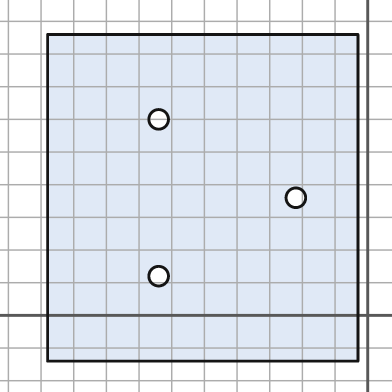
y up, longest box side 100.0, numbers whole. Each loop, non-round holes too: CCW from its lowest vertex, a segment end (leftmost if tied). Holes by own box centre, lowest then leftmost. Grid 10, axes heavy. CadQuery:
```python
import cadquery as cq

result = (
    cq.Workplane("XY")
    .moveTo(-98.0, -14.0)
    .lineTo(-3.0, -14.0)
    .lineTo(-3.0, 86.0)
    .lineTo(-98.0, 86.0)
    .close()
    .moveTo(-64.0, 12.0)
    .circle(3.0)
    .moveTo(-22.0, 36.0)
    .circle(3.0)
    .moveTo(-64.0, 60.0)
    .circle(3.0)
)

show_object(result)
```